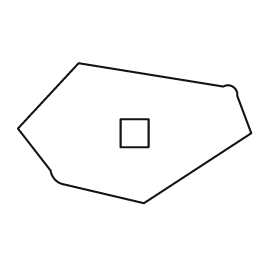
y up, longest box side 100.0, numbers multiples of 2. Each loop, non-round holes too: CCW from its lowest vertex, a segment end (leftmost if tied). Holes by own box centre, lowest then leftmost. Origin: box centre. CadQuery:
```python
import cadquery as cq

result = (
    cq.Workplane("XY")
    .moveTo(4.0, -30.0)
    .lineTo(50.0, 0.0)
    .lineTo(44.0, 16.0)
    .threePointArc((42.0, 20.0), (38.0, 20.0))
    .lineTo(-24.0, 30.0)
    .lineTo(-50.0, 2.0)
    .lineTo(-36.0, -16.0)
    .threePointArc((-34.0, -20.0), (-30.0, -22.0))
    .close()
    .moveTo(-6.0, -6.0)
    .lineTo(6.0, -6.0)
    .lineTo(6.0, 6.0)
    .lineTo(-6.0, 6.0)
    .close()
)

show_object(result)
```